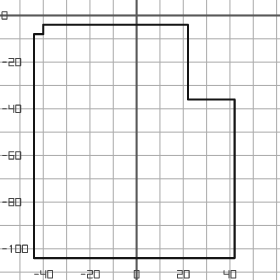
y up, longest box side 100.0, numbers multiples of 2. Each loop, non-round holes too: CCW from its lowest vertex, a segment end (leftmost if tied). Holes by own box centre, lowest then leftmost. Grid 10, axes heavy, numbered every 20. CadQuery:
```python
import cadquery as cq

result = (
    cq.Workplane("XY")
    .moveTo(-44.0, -104.0)
    .lineTo(42.0, -104.0)
    .lineTo(42.0, -36.0)
    .lineTo(22.0, -36.0)
    .lineTo(22.0, -4.0)
    .lineTo(-40.0, -4.0)
    .lineTo(-40.0, -8.0)
    .lineTo(-44.0, -8.0)
    .close()
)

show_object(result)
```